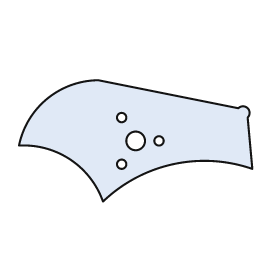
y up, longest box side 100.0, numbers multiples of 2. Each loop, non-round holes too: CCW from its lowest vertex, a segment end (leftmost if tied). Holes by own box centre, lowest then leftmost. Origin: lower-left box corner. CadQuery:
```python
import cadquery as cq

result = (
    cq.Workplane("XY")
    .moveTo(36.0, 0.0)
    .threePointArc((66.0, 16.0), (100.0, 14.0))
    .lineTo(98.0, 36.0)
    .threePointArc((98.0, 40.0), (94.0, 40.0))
    .lineTo(34.0, 52.0)
    .threePointArc((12.0, 44.0), (0.0, 24.0))
    .threePointArc((22.0, 18.0), (36.0, 0.0))
    .close()
    .moveTo(44.0, 16.0)
    .circle(2.0)
    .moveTo(50.0, 26.0)
    .circle(4.0)
    .moveTo(60.0, 26.0)
    .circle(2.0)
    .moveTo(44.0, 36.0)
    .circle(2.0)
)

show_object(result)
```